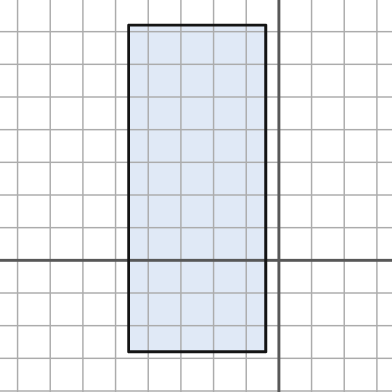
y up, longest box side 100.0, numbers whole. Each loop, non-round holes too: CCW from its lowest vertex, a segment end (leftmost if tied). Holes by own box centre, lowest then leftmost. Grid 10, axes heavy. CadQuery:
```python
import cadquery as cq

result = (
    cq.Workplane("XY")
    .moveTo(-46.0, -28.0)
    .lineTo(-4.0, -28.0)
    .lineTo(-4.0, 72.0)
    .lineTo(-46.0, 72.0)
    .close()
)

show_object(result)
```